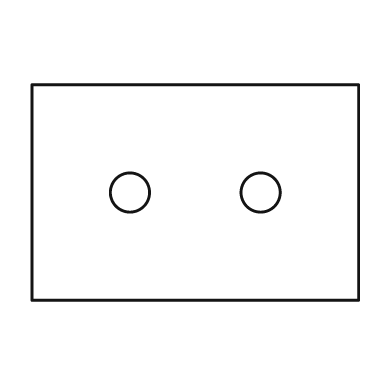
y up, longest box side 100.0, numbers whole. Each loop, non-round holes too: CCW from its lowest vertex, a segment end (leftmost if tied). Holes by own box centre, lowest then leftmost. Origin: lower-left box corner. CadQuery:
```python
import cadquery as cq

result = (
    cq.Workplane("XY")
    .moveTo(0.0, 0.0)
    .lineTo(100.0, 0.0)
    .lineTo(100.0, 66.0)
    .lineTo(0.0, 66.0)
    .close()
    .moveTo(30.0, 33.0)
    .circle(6.0)
    .moveTo(70.0, 33.0)
    .circle(6.0)
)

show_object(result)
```